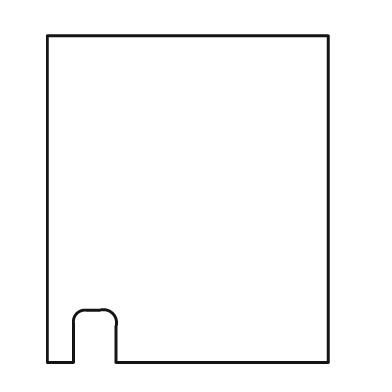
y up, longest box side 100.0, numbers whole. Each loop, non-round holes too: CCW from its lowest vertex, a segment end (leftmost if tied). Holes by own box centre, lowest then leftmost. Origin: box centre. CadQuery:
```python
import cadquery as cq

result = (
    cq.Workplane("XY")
    .moveTo(-43.0, -50.0)
    .lineTo(-35.0, -50.0)
    .lineTo(-35.0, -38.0)
    .threePointArc((-34.0, -35.0), (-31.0, -34.0))
    .lineTo(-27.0, -34.0)
    .threePointArc((-23.0, -35.0), (-22.0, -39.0))
    .lineTo(-22.0, -50.0)
    .lineTo(43.0, -50.0)
    .lineTo(43.0, 50.0)
    .lineTo(-43.0, 50.0)
    .close()
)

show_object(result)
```